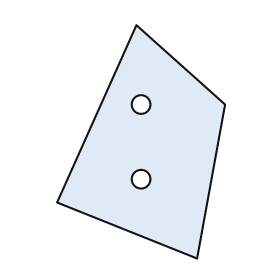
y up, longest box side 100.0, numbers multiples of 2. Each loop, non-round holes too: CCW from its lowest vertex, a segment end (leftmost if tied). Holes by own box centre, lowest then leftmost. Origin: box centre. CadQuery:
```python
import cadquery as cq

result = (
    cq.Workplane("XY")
    .moveTo(24.0, -50.0)
    .lineTo(36.0, 16.0)
    .lineTo(-2.0, 50.0)
    .lineTo(-36.0, -26.0)
    .close()
    .moveTo(0.0, -16.0)
    .circle(4.0)
    .moveTo(0.0, 16.0)
    .circle(4.0)
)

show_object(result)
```